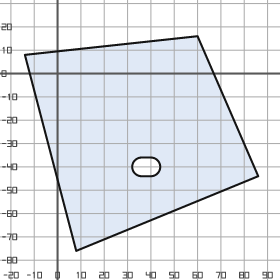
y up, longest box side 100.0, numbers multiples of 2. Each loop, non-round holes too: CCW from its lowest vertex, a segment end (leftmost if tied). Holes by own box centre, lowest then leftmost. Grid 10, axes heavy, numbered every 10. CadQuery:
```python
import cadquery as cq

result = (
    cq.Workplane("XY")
    .moveTo(8.0, -76.0)
    .lineTo(86.0, -44.0)
    .lineTo(60.0, 16.0)
    .lineTo(-14.0, 8.0)
    .close()
    .moveTo(36.0, -44.0)
    .lineTo(40.0, -44.0)
    .threePointArc((44.0, -40.0), (40.0, -36.0))
    .lineTo(36.0, -36.0)
    .threePointArc((32.0, -40.0), (36.0, -44.0))
    .close()
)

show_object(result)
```